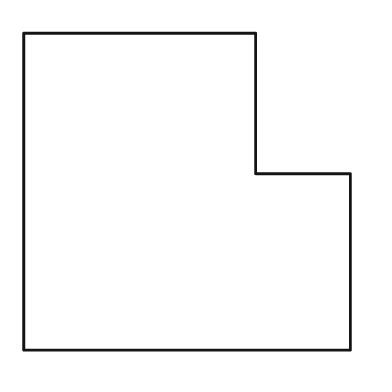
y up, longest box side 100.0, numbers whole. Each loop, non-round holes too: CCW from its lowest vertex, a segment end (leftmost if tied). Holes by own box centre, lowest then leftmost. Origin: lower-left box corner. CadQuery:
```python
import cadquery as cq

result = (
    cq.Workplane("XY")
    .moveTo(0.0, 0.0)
    .lineTo(100.0, 0.0)
    .lineTo(100.0, 54.0)
    .lineTo(71.0, 54.0)
    .lineTo(71.0, 97.0)
    .lineTo(0.0, 97.0)
    .close()
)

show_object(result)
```